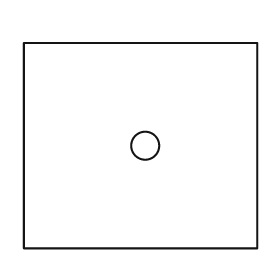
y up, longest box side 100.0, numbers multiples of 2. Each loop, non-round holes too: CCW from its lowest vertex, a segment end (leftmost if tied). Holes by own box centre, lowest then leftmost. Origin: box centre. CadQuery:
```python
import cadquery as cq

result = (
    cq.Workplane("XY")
    .moveTo(-50.0, -44.0)
    .lineTo(50.0, -44.0)
    .lineTo(50.0, 44.0)
    .lineTo(-50.0, 44.0)
    .close()
    .moveTo(2.0, 0.0)
    .circle(6.0)
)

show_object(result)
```